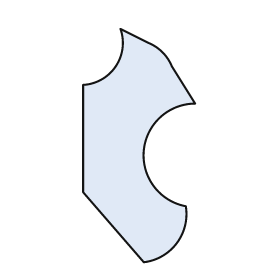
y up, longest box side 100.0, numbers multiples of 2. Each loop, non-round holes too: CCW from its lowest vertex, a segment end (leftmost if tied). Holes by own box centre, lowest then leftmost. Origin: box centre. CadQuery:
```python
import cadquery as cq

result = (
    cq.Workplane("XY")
    .moveTo(2.0, -50.0)
    .threePointArc((16.0, -42.0), (20.0, -26.0))
    .threePointArc((2.0, -2.0), (24.0, 18.0))
    .lineTo(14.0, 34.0)
    .threePointArc((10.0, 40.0), (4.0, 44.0))
    .lineTo(-8.0, 50.0)
    .threePointArc((-10.0, 34.0), (-24.0, 26.0))
    .lineTo(-24.0, -20.0)
    .close()
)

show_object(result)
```